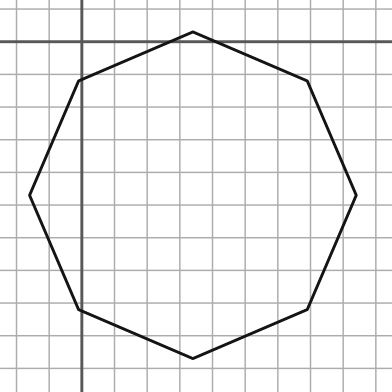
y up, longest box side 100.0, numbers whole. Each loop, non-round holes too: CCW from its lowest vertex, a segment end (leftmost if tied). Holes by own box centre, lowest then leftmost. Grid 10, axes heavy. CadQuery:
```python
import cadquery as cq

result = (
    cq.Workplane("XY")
    .moveTo(34.0, -97.0)
    .lineTo(69.0, -82.0)
    .lineTo(84.0, -47.0)
    .lineTo(69.0, -12.0)
    .lineTo(34.0, 3.0)
    .lineTo(-1.0, -12.0)
    .lineTo(-16.0, -47.0)
    .lineTo(-1.0, -82.0)
    .close()
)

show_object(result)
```